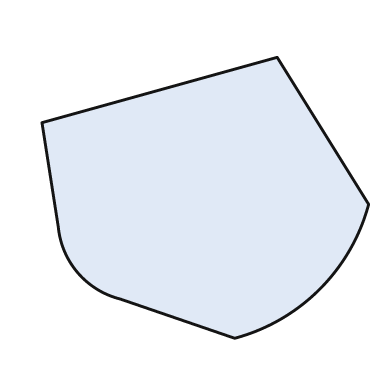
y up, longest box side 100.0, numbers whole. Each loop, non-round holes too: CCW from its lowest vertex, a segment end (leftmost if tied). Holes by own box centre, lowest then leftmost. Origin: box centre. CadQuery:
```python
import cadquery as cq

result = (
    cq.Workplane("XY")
    .moveTo(9.0, -43.0)
    .threePointArc((35.0, -28.0), (50.0, -2.0))
    .lineTo(22.0, 43.0)
    .lineTo(-50.0, 23.0)
    .lineTo(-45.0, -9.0)
    .threePointArc((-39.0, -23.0), (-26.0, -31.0))
    .close()
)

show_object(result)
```